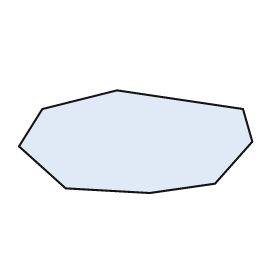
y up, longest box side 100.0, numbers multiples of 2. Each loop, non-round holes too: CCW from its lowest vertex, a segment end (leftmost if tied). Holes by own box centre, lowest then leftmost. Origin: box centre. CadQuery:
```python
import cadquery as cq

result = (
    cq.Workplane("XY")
    .moveTo(6.0, -22.0)
    .lineTo(34.0, -18.0)
    .lineTo(50.0, 0.0)
    .lineTo(46.0, 14.0)
    .lineTo(-8.0, 22.0)
    .lineTo(-40.0, 14.0)
    .lineTo(-50.0, -2.0)
    .lineTo(-30.0, -20.0)
    .close()
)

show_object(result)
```